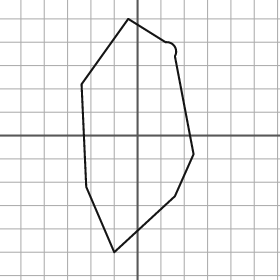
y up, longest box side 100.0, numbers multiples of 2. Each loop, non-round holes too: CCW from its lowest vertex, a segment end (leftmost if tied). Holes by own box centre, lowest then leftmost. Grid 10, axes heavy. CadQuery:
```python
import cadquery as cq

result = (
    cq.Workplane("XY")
    .moveTo(-10.0, -50.0)
    .lineTo(16.0, -26.0)
    .lineTo(24.0, -8.0)
    .lineTo(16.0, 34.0)
    .threePointArc((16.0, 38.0), (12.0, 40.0))
    .lineTo(-4.0, 50.0)
    .lineTo(-24.0, 22.0)
    .lineTo(-22.0, -22.0)
    .close()
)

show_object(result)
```